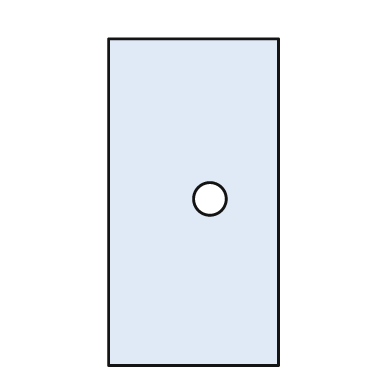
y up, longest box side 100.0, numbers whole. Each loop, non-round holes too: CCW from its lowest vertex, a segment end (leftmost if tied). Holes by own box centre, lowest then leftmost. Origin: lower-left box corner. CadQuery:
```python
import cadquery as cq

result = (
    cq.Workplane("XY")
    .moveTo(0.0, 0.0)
    .lineTo(52.0, 0.0)
    .lineTo(52.0, 100.0)
    .lineTo(0.0, 100.0)
    .close()
    .moveTo(31.0, 51.0)
    .circle(5.0)
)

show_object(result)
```